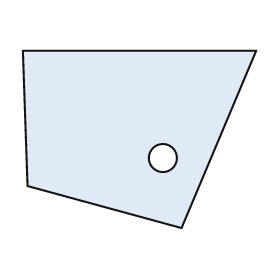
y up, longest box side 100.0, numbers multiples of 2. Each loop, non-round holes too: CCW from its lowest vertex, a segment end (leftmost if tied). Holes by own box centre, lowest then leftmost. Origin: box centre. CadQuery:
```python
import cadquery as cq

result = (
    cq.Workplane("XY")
    .moveTo(18.0, -38.0)
    .lineTo(50.0, 38.0)
    .lineTo(-50.0, 38.0)
    .lineTo(-48.0, -20.0)
    .close()
    .moveTo(10.0, -8.0)
    .circle(6.0)
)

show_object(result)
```